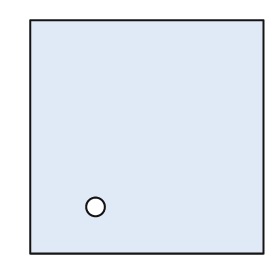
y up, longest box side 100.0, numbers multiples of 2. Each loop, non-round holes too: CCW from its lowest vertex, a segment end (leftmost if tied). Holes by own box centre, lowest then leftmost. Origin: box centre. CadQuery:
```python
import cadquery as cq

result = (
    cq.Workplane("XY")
    .moveTo(-50.0, -50.0)
    .lineTo(50.0, -50.0)
    .lineTo(50.0, 50.0)
    .lineTo(-50.0, 50.0)
    .close()
    .moveTo(-22.0, -30.0)
    .circle(4.0)
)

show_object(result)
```